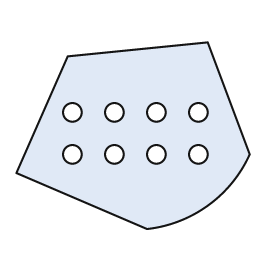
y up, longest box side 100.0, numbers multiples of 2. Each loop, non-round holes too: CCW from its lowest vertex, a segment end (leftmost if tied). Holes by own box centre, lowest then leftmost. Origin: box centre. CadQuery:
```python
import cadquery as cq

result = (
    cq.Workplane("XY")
    .moveTo(6.0, -40.0)
    .threePointArc((32.0, -30.0), (50.0, -8.0))
    .lineTo(32.0, 40.0)
    .lineTo(-28.0, 34.0)
    .lineTo(-50.0, -16.0)
    .close()
    .moveTo(-26.0, -8.0)
    .circle(4.0)
    .moveTo(-8.0, -8.0)
    .circle(4.0)
    .moveTo(10.0, -8.0)
    .circle(4.0)
    .moveTo(28.0, -8.0)
    .circle(4.0)
    .moveTo(-26.0, 10.0)
    .circle(4.0)
    .moveTo(-8.0, 10.0)
    .circle(4.0)
    .moveTo(10.0, 10.0)
    .circle(4.0)
    .moveTo(28.0, 10.0)
    .circle(4.0)
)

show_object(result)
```